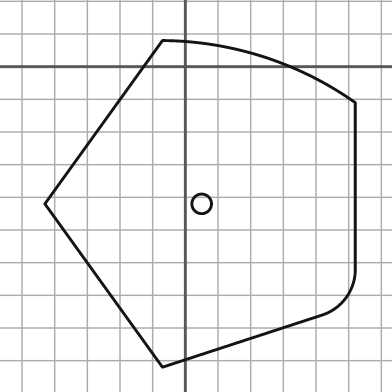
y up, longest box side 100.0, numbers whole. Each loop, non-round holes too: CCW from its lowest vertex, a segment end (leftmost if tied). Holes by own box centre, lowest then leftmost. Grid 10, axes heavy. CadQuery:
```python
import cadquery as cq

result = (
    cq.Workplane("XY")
    .moveTo(-7.0, -92.0)
    .lineTo(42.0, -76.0)
    .threePointArc((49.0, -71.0), (52.0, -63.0))
    .lineTo(52.0, -11.0)
    .threePointArc((24.0, 3.0), (-7.0, 8.0))
    .lineTo(-43.0, -42.0)
    .close()
    .moveTo(5.0, -42.0)
    .circle(3.0)
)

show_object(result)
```